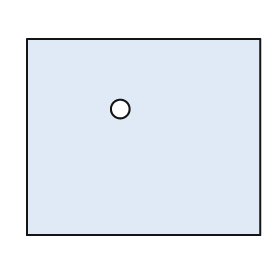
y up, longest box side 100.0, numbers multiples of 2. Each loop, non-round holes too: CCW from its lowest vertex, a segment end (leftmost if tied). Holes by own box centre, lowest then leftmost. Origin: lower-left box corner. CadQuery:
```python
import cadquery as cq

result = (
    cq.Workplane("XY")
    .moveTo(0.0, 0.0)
    .lineTo(100.0, 0.0)
    .lineTo(100.0, 84.0)
    .lineTo(0.0, 84.0)
    .close()
    .moveTo(40.0, 54.0)
    .circle(4.0)
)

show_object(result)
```